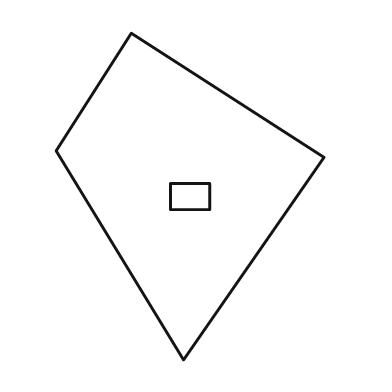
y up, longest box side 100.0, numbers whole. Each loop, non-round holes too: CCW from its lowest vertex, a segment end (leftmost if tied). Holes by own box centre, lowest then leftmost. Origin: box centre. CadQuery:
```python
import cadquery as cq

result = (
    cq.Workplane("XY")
    .moveTo(-2.0, -50.0)
    .lineTo(41.0, 12.0)
    .lineTo(-18.0, 50.0)
    .lineTo(-41.0, 14.0)
    .close()
    .moveTo(-6.0, -4.0)
    .lineTo(6.0, -4.0)
    .lineTo(6.0, 4.0)
    .lineTo(-6.0, 4.0)
    .close()
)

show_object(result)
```